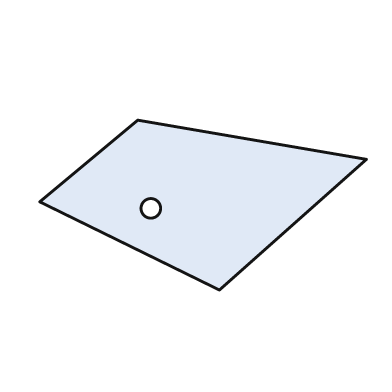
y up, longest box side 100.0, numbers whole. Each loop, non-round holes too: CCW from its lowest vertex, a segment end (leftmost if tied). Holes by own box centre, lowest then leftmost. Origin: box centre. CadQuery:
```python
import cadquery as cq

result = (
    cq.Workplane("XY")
    .moveTo(5.0, -26.0)
    .lineTo(50.0, 14.0)
    .lineTo(-20.0, 26.0)
    .lineTo(-50.0, 1.0)
    .close()
    .moveTo(-16.0, -1.0)
    .circle(3.0)
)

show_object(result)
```